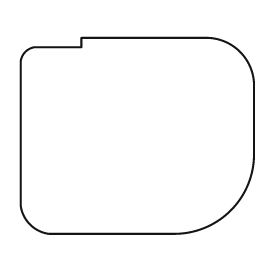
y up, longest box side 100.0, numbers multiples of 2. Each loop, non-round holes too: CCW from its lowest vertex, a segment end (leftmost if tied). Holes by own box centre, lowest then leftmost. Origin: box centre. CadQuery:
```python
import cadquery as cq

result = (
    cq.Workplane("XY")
    .moveTo(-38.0, -42.0)
    .lineTo(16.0, -42.0)
    .threePointArc((40.0, -32.0), (50.0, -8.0))
    .lineTo(50.0, 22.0)
    .threePointArc((44.0, 36.0), (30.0, 42.0))
    .lineTo(-24.0, 42.0)
    .lineTo(-24.0, 38.0)
    .lineTo(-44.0, 38.0)
    .threePointArc((-48.0, 36.0), (-50.0, 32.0))
    .lineTo(-50.0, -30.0)
    .threePointArc((-46.0, -38.0), (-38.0, -42.0))
    .close()
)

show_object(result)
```